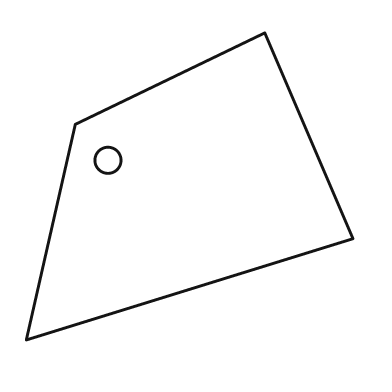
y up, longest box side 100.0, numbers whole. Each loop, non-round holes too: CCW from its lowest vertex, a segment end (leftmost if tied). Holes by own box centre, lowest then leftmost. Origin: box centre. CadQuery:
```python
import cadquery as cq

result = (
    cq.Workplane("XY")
    .moveTo(-50.0, -47.0)
    .lineTo(50.0, -16.0)
    .lineTo(23.0, 47.0)
    .lineTo(-35.0, 19.0)
    .close()
    .moveTo(-25.0, 8.0)
    .circle(4.0)
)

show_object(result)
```